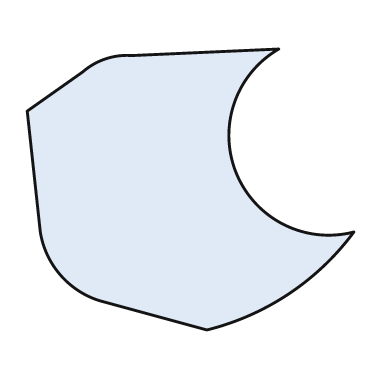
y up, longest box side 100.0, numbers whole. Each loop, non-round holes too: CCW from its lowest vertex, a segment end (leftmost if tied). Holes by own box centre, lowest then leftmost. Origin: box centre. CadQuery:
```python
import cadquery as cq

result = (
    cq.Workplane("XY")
    .moveTo(5.0, -43.0)
    .threePointArc((30.0, -32.0), (50.0, -13.0))
    .threePointArc((14.0, 5.0), (27.0, 43.0))
    .lineTo(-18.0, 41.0)
    .threePointArc((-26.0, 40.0), (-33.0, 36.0))
    .lineTo(-50.0, 24.0)
    .lineTo(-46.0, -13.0)
    .threePointArc((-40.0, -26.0), (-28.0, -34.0))
    .close()
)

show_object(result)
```